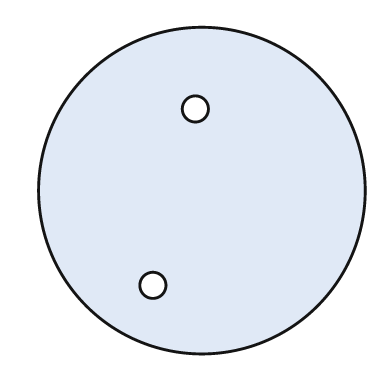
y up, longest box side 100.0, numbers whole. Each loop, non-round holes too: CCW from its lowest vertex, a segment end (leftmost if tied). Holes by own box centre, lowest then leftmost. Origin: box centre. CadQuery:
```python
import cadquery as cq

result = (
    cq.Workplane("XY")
    .moveTo(0.0, 0.0)
    .circle(50.0)
    .moveTo(-15.0, -29.0)
    .circle(4.0)
    .moveTo(-2.0, 25.0)
    .circle(4.0)
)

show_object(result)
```